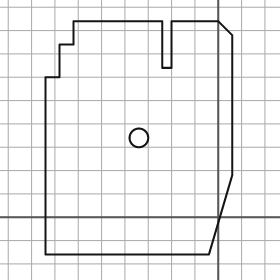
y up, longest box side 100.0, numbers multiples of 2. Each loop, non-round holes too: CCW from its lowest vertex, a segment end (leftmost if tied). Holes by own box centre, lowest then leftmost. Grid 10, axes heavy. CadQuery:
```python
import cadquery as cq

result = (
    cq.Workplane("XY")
    .moveTo(-74.0, -16.0)
    .lineTo(-4.0, -16.0)
    .lineTo(6.0, 18.0)
    .lineTo(6.0, 78.0)
    .lineTo(0.0, 84.0)
    .lineTo(-20.0, 84.0)
    .lineTo(-20.0, 64.0)
    .lineTo(-24.0, 64.0)
    .lineTo(-24.0, 84.0)
    .lineTo(-62.0, 84.0)
    .lineTo(-62.0, 74.0)
    .lineTo(-68.0, 74.0)
    .lineTo(-68.0, 60.0)
    .lineTo(-74.0, 60.0)
    .close()
    .moveTo(-34.0, 34.0)
    .circle(4.0)
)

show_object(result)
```